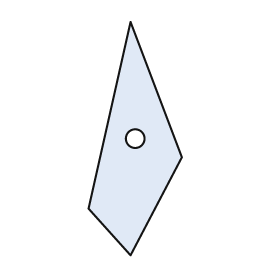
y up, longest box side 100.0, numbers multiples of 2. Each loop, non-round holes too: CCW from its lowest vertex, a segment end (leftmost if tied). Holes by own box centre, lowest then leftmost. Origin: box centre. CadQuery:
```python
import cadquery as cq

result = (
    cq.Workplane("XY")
    .moveTo(-2.0, -50.0)
    .lineTo(20.0, -8.0)
    .lineTo(-2.0, 50.0)
    .lineTo(-20.0, -30.0)
    .close()
    .moveTo(0.0, 0.0)
    .circle(4.0)
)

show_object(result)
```